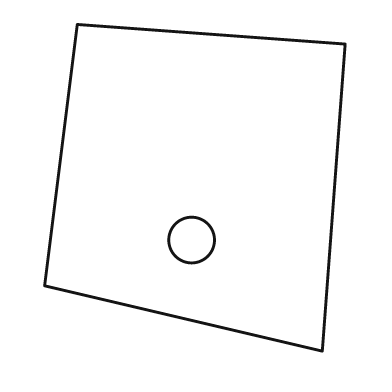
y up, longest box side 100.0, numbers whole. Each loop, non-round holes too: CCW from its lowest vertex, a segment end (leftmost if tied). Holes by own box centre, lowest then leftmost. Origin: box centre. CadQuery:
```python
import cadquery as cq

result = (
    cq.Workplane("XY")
    .moveTo(39.0, -50.0)
    .lineTo(46.0, 44.0)
    .lineTo(-36.0, 50.0)
    .lineTo(-46.0, -30.0)
    .close()
    .moveTo(-1.0, -16.0)
    .circle(7.0)
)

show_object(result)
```